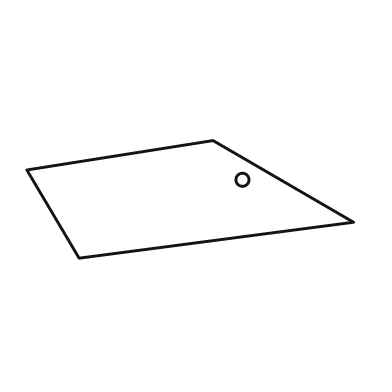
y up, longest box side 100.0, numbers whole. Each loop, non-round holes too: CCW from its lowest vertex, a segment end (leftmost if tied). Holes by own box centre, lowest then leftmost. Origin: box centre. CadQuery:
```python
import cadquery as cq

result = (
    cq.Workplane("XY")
    .moveTo(-34.0, -18.0)
    .lineTo(50.0, -7.0)
    .lineTo(7.0, 18.0)
    .lineTo(-50.0, 9.0)
    .close()
    .moveTo(16.0, 6.0)
    .circle(2.0)
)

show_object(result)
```